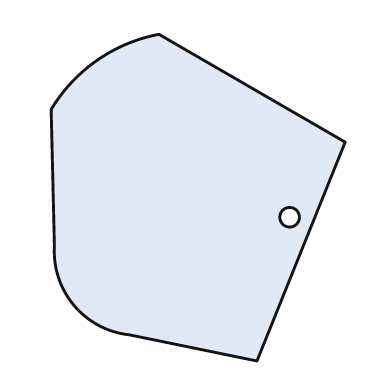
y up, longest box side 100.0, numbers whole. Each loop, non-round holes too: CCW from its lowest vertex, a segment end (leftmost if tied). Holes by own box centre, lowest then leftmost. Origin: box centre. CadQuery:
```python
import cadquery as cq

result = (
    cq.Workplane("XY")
    .moveTo(18.0, -50.0)
    .lineTo(45.0, 17.0)
    .lineTo(-12.0, 50.0)
    .threePointArc((-31.0, 42.0), (-45.0, 27.0))
    .lineTo(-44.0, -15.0)
    .threePointArc((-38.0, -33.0), (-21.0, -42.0))
    .close()
    .moveTo(28.0, -6.0)
    .circle(3.0)
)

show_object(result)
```